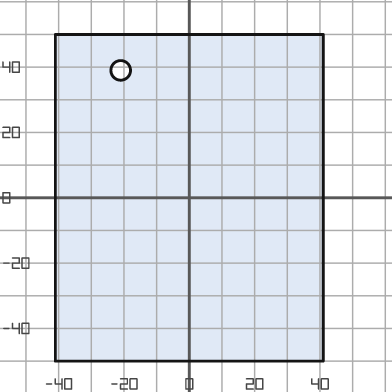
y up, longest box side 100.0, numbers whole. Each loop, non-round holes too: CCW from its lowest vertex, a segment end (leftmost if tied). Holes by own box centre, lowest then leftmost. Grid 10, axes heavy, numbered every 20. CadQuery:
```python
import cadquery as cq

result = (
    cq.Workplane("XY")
    .moveTo(-41.0, -50.0)
    .lineTo(41.0, -50.0)
    .lineTo(41.0, 50.0)
    .lineTo(-41.0, 50.0)
    .close()
    .moveTo(-21.0, 39.0)
    .circle(3.0)
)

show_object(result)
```